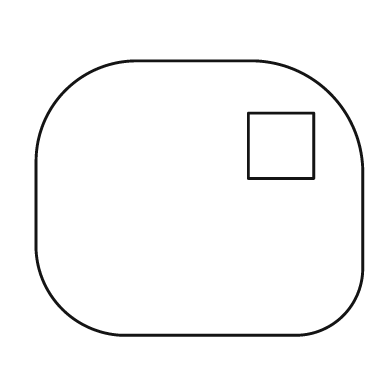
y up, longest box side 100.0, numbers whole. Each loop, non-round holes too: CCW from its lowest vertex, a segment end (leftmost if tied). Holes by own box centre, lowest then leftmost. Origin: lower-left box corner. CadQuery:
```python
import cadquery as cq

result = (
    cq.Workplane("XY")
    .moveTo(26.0, 0.0)
    .lineTo(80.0, 0.0)
    .threePointArc((94.0, 6.0), (100.0, 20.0))
    .lineTo(100.0, 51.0)
    .threePointArc((90.0, 74.0), (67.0, 84.0))
    .lineTo(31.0, 84.0)
    .threePointArc((9.0, 75.0), (0.0, 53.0))
    .lineTo(0.0, 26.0)
    .threePointArc((8.0, 8.0), (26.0, 0.0))
    .close()
    .moveTo(65.0, 48.0)
    .lineTo(85.0, 48.0)
    .lineTo(85.0, 68.0)
    .lineTo(65.0, 68.0)
    .close()
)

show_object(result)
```